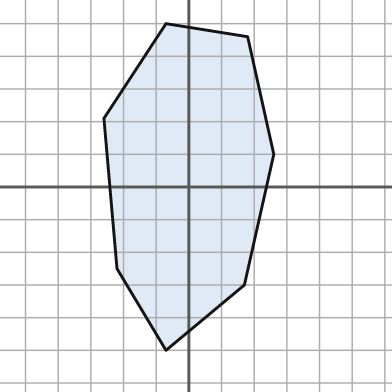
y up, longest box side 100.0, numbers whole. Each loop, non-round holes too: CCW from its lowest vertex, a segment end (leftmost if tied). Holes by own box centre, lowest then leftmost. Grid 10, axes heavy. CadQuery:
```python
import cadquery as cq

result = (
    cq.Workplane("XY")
    .moveTo(-7.0, -50.0)
    .lineTo(17.0, -30.0)
    .lineTo(26.0, 10.0)
    .lineTo(18.0, 46.0)
    .lineTo(-7.0, 50.0)
    .lineTo(-26.0, 21.0)
    .lineTo(-22.0, -25.0)
    .close()
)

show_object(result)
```